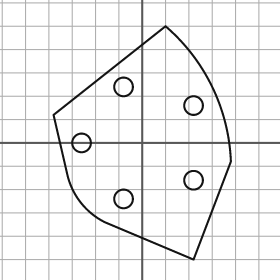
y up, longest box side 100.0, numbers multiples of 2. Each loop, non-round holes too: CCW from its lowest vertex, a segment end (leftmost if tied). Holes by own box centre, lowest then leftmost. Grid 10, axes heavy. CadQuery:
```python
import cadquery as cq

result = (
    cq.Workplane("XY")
    .moveTo(22.0, -50.0)
    .lineTo(38.0, -8.0)
    .threePointArc((30.0, 24.0), (10.0, 50.0))
    .lineTo(-38.0, 12.0)
    .lineTo(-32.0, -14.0)
    .threePointArc((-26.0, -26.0), (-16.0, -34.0))
    .close()
    .moveTo(-8.0, -24.0)
    .circle(4.0)
    .moveTo(22.0, -16.0)
    .circle(4.0)
    .moveTo(-26.0, 0.0)
    .circle(4.0)
    .moveTo(22.0, 16.0)
    .circle(4.0)
    .moveTo(-8.0, 24.0)
    .circle(4.0)
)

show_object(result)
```